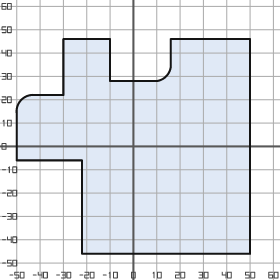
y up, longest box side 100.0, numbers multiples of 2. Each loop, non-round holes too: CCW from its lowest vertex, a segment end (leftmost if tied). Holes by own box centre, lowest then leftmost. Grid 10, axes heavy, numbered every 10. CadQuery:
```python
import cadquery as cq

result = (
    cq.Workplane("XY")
    .moveTo(-22.0, -46.0)
    .lineTo(50.0, -46.0)
    .lineTo(50.0, 46.0)
    .lineTo(16.0, 46.0)
    .lineTo(16.0, 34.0)
    .threePointArc((14.0, 30.0), (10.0, 28.0))
    .lineTo(-10.0, 28.0)
    .lineTo(-10.0, 46.0)
    .lineTo(-30.0, 46.0)
    .lineTo(-30.0, 22.0)
    .lineTo(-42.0, 22.0)
    .threePointArc((-48.0, 20.0), (-50.0, 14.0))
    .lineTo(-50.0, -6.0)
    .lineTo(-22.0, -6.0)
    .close()
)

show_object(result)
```